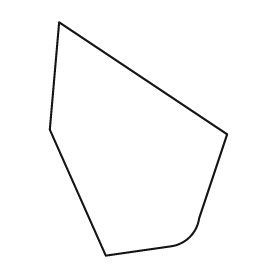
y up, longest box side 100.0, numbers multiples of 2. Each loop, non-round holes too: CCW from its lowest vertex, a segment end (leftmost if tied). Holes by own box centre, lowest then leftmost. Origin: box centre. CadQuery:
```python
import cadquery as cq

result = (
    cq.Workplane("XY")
    .moveTo(-14.0, -50.0)
    .lineTo(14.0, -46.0)
    .threePointArc((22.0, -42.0), (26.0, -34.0))
    .lineTo(38.0, 2.0)
    .lineTo(-34.0, 50.0)
    .lineTo(-38.0, 4.0)
    .close()
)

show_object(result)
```